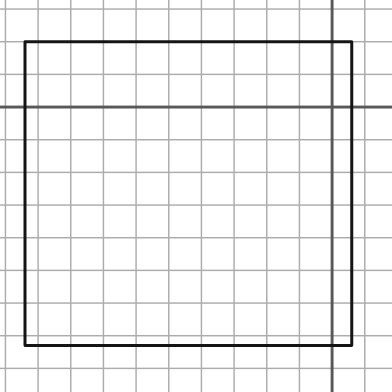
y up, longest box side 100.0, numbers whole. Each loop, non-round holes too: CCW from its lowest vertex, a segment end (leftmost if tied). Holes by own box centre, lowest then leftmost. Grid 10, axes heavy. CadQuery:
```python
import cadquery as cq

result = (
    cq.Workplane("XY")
    .moveTo(-94.0, -73.0)
    .lineTo(6.0, -73.0)
    .lineTo(6.0, 20.0)
    .lineTo(-94.0, 20.0)
    .close()
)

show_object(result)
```